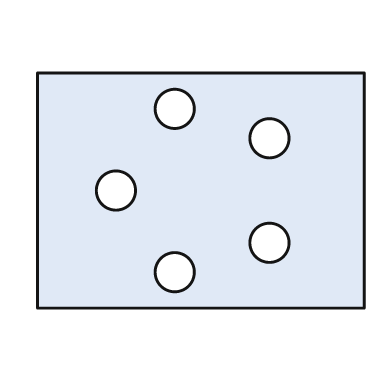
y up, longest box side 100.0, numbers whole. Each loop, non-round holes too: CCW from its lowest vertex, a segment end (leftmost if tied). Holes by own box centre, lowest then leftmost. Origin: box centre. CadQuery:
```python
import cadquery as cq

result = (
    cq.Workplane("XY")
    .moveTo(-50.0, -36.0)
    .lineTo(50.0, -36.0)
    .lineTo(50.0, 36.0)
    .lineTo(-50.0, 36.0)
    .close()
    .moveTo(-8.0, -25.0)
    .circle(6.0)
    .moveTo(21.0, -16.0)
    .circle(6.0)
    .moveTo(-26.0, 0.0)
    .circle(6.0)
    .moveTo(21.0, 16.0)
    .circle(6.0)
    .moveTo(-8.0, 25.0)
    .circle(6.0)
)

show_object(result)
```